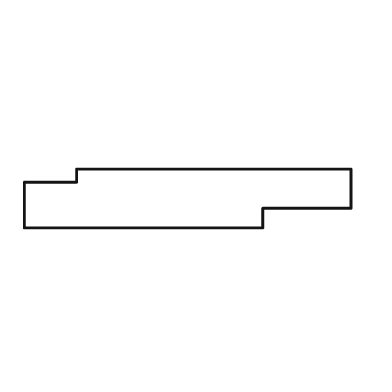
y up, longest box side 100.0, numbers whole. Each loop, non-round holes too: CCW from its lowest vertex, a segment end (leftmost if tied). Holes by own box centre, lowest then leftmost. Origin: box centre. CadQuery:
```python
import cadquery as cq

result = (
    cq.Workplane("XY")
    .moveTo(-50.0, -9.0)
    .lineTo(23.0, -9.0)
    .lineTo(23.0, -3.0)
    .lineTo(50.0, -3.0)
    .lineTo(50.0, 9.0)
    .lineTo(-34.0, 9.0)
    .lineTo(-34.0, 5.0)
    .lineTo(-50.0, 5.0)
    .close()
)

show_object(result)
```